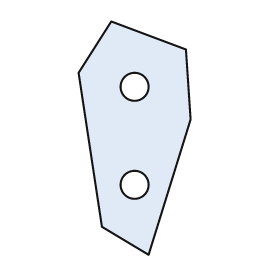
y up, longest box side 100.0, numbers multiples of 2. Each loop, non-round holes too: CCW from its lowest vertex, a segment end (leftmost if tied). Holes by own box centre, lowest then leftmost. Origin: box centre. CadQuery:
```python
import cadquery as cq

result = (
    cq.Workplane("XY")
    .moveTo(6.0, -50.0)
    .lineTo(24.0, 8.0)
    .lineTo(22.0, 38.0)
    .lineTo(-10.0, 50.0)
    .lineTo(-24.0, 28.0)
    .lineTo(-14.0, -38.0)
    .close()
    .moveTo(0.0, -20.0)
    .circle(6.0)
    .moveTo(0.0, 22.0)
    .circle(6.0)
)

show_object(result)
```